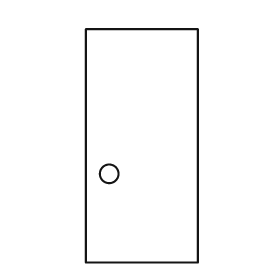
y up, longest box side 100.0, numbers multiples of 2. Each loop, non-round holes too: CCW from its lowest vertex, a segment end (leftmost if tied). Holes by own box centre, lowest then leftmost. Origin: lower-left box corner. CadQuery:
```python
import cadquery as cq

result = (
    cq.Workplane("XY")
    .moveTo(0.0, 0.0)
    .lineTo(48.0, 0.0)
    .lineTo(48.0, 100.0)
    .lineTo(0.0, 100.0)
    .close()
    .moveTo(10.0, 38.0)
    .circle(4.0)
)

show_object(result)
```